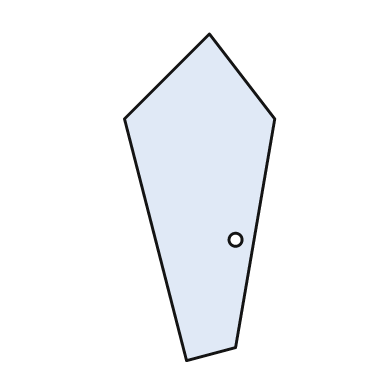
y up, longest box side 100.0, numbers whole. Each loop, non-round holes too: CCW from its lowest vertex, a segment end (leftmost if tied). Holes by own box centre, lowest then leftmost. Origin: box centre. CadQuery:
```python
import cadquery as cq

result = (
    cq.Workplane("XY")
    .moveTo(-4.0, -50.0)
    .lineTo(11.0, -46.0)
    .lineTo(23.0, 24.0)
    .lineTo(3.0, 50.0)
    .lineTo(-23.0, 24.0)
    .close()
    .moveTo(11.0, -13.0)
    .circle(2.0)
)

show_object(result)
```